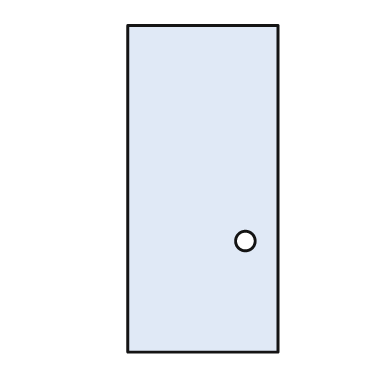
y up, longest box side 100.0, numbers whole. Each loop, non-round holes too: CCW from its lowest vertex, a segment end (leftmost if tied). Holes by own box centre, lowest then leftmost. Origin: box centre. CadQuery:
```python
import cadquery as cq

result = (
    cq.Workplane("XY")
    .moveTo(-23.0, -50.0)
    .lineTo(23.0, -50.0)
    .lineTo(23.0, 50.0)
    .lineTo(-23.0, 50.0)
    .close()
    .moveTo(13.0, -16.0)
    .circle(3.0)
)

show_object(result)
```